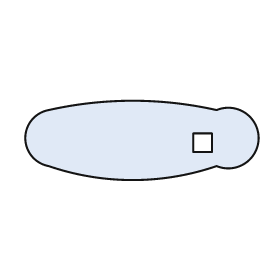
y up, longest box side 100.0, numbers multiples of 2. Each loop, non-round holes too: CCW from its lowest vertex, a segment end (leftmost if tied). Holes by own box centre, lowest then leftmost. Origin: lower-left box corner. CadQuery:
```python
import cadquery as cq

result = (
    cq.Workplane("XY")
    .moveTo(10.0, 6.0)
    .threePointArc((46.0, 0.0), (82.0, 6.0))
    .threePointArc((100.0, 18.0), (82.0, 30.0))
    .threePointArc((46.0, 34.0), (10.0, 30.0))
    .threePointArc((0.0, 18.0), (10.0, 6.0))
    .close()
    .moveTo(72.0, 12.0)
    .lineTo(80.0, 12.0)
    .lineTo(80.0, 20.0)
    .lineTo(72.0, 20.0)
    .close()
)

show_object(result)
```